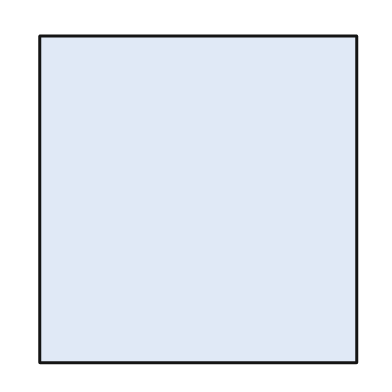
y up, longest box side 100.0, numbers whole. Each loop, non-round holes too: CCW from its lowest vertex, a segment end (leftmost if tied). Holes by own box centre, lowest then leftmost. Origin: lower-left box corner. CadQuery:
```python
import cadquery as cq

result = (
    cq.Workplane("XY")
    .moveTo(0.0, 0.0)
    .lineTo(97.0, 0.0)
    .lineTo(97.0, 100.0)
    .lineTo(0.0, 100.0)
    .close()
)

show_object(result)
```